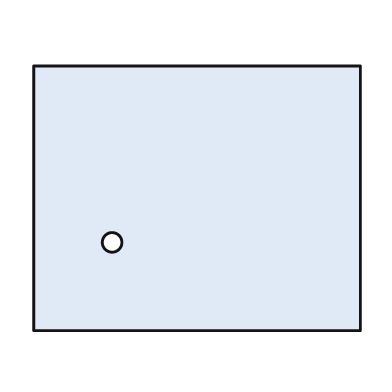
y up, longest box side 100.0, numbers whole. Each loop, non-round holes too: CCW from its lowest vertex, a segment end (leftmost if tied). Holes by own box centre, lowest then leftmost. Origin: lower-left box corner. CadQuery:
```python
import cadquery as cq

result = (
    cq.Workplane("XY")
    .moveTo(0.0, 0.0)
    .lineTo(100.0, 0.0)
    .lineTo(100.0, 81.0)
    .lineTo(0.0, 81.0)
    .close()
    .moveTo(24.0, 27.0)
    .circle(3.0)
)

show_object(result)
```